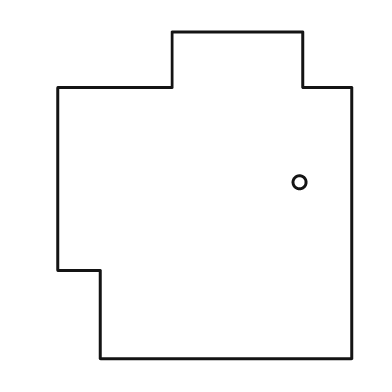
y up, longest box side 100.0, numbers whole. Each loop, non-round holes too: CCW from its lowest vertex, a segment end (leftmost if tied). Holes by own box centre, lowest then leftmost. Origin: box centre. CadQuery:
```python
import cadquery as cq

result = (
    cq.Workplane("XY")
    .moveTo(-32.0, -50.0)
    .lineTo(45.0, -50.0)
    .lineTo(45.0, 33.0)
    .lineTo(30.0, 33.0)
    .lineTo(30.0, 50.0)
    .lineTo(-10.0, 50.0)
    .lineTo(-10.0, 33.0)
    .lineTo(-45.0, 33.0)
    .lineTo(-45.0, -23.0)
    .lineTo(-32.0, -23.0)
    .close()
    .moveTo(29.0, 4.0)
    .circle(2.0)
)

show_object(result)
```